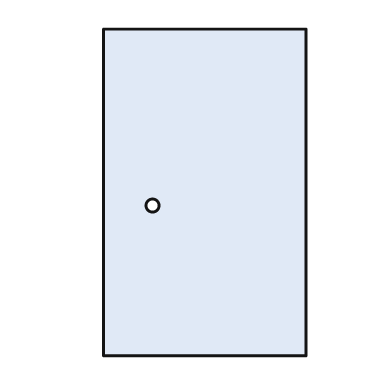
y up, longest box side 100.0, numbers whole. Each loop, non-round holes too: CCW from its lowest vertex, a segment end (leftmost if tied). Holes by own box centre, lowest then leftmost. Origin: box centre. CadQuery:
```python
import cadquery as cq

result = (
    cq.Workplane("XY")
    .moveTo(-31.0, -50.0)
    .lineTo(31.0, -50.0)
    .lineTo(31.0, 50.0)
    .lineTo(-31.0, 50.0)
    .close()
    .moveTo(-16.0, -4.0)
    .circle(2.0)
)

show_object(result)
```